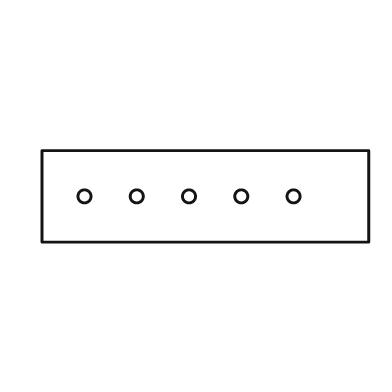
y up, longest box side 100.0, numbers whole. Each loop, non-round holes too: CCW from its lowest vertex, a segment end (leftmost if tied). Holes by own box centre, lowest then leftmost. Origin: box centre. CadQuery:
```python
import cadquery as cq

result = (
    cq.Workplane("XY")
    .moveTo(-50.0, -14.0)
    .lineTo(50.0, -14.0)
    .lineTo(50.0, 14.0)
    .lineTo(-50.0, 14.0)
    .close()
    .moveTo(-37.0, 0.0)
    .circle(2.0)
    .moveTo(-21.0, 0.0)
    .circle(2.0)
    .moveTo(-5.0, 0.0)
    .circle(2.0)
    .moveTo(11.0, 0.0)
    .circle(2.0)
    .moveTo(27.0, 0.0)
    .circle(2.0)
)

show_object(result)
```